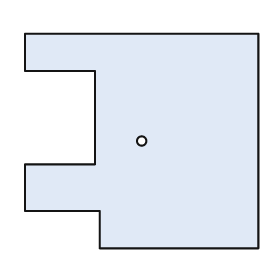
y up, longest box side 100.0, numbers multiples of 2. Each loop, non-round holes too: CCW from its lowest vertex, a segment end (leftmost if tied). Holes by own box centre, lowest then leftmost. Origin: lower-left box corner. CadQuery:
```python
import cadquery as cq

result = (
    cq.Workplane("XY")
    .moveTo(32.0, 0.0)
    .lineTo(100.0, 0.0)
    .lineTo(100.0, 92.0)
    .lineTo(0.0, 92.0)
    .lineTo(0.0, 76.0)
    .lineTo(30.0, 76.0)
    .lineTo(30.0, 36.0)
    .lineTo(0.0, 36.0)
    .lineTo(0.0, 16.0)
    .lineTo(32.0, 16.0)
    .close()
    .moveTo(50.0, 46.0)
    .circle(2.0)
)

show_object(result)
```